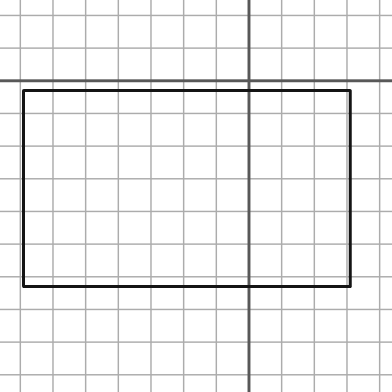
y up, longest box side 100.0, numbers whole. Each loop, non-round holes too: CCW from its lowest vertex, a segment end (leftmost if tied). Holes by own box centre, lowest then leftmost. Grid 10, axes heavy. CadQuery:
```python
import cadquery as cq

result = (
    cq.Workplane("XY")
    .moveTo(-69.0, -63.0)
    .lineTo(31.0, -63.0)
    .lineTo(31.0, -3.0)
    .lineTo(-69.0, -3.0)
    .close()
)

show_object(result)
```